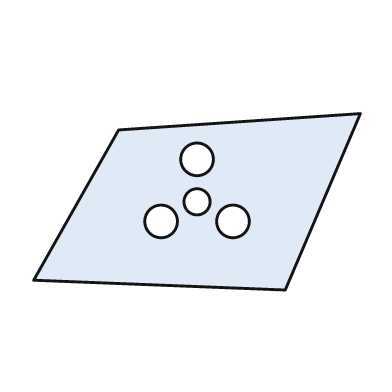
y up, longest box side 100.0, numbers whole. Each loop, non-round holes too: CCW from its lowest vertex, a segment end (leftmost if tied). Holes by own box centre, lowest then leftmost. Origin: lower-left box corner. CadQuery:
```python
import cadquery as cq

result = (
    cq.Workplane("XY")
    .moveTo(77.0, 0.0)
    .lineTo(100.0, 54.0)
    .lineTo(26.0, 49.0)
    .lineTo(0.0, 3.0)
    .close()
    .moveTo(39.0, 21.0)
    .circle(5.0)
    .moveTo(61.0, 21.0)
    .circle(5.0)
    .moveTo(50.0, 27.0)
    .circle(4.0)
    .moveTo(50.0, 40.0)
    .circle(5.0)
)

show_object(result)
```